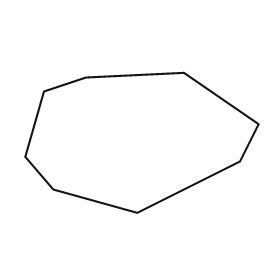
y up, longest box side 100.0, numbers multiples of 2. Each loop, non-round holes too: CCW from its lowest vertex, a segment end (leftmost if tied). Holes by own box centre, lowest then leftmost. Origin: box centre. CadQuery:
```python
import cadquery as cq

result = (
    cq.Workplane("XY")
    .moveTo(-2.0, -30.0)
    .lineTo(42.0, -8.0)
    .lineTo(50.0, 8.0)
    .lineTo(18.0, 30.0)
    .lineTo(-24.0, 28.0)
    .lineTo(-42.0, 22.0)
    .lineTo(-50.0, -6.0)
    .lineTo(-38.0, -20.0)
    .close()
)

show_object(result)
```